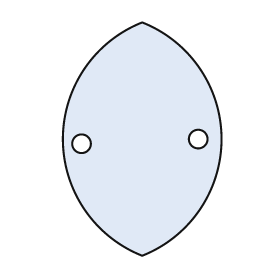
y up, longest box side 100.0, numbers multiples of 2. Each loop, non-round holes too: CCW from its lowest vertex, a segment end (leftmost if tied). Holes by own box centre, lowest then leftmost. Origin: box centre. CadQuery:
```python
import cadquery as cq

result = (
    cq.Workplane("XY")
    .moveTo(0.0, -50.0)
    .threePointArc((34.0, 0.0), (0.0, 50.0))
    .threePointArc((-34.0, 0.0), (0.0, -50.0))
    .close()
    .moveTo(-26.0, -2.0)
    .circle(4.0)
    .moveTo(24.0, 0.0)
    .circle(4.0)
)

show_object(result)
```